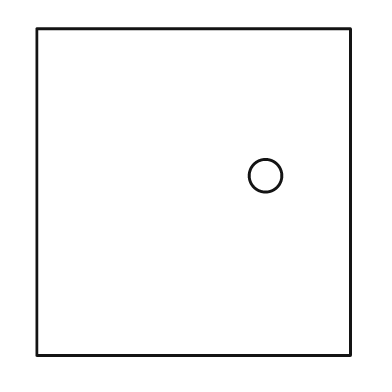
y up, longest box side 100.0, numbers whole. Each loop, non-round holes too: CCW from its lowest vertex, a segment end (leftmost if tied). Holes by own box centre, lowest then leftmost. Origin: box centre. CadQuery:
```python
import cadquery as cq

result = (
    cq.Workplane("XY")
    .moveTo(-48.0, -50.0)
    .lineTo(48.0, -50.0)
    .lineTo(48.0, 50.0)
    .lineTo(-48.0, 50.0)
    .close()
    .moveTo(22.0, 5.0)
    .circle(5.0)
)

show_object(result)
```